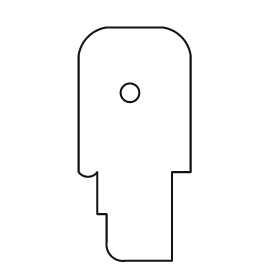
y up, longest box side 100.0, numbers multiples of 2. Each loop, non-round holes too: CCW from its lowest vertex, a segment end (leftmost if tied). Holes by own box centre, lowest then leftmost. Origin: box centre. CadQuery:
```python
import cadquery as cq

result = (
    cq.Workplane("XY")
    .moveTo(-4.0, -50.0)
    .lineTo(16.0, -50.0)
    .lineTo(16.0, -12.0)
    .lineTo(24.0, -12.0)
    .lineTo(24.0, 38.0)
    .threePointArc((20.0, 46.0), (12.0, 50.0))
    .lineTo(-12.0, 50.0)
    .threePointArc((-20.0, 46.0), (-24.0, 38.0))
    .lineTo(-24.0, -12.0)
    .threePointArc((-20.0, -14.0), (-16.0, -12.0))
    .lineTo(-16.0, -30.0)
    .lineTo(-12.0, -30.0)
    .lineTo(-12.0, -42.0)
    .threePointArc((-10.0, -48.0), (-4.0, -50.0))
    .close()
    .moveTo(-2.0, 22.0)
    .circle(4.0)
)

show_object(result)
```